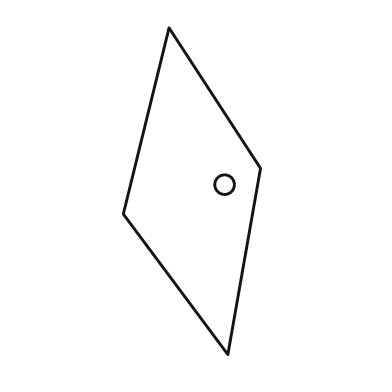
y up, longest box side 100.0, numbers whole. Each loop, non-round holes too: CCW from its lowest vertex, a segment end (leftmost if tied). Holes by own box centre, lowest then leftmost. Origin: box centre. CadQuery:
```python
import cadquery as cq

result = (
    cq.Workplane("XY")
    .moveTo(11.0, -50.0)
    .lineTo(21.0, 7.0)
    .lineTo(-7.0, 50.0)
    .lineTo(-21.0, -7.0)
    .close()
    .moveTo(10.0, 2.0)
    .circle(3.0)
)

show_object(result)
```